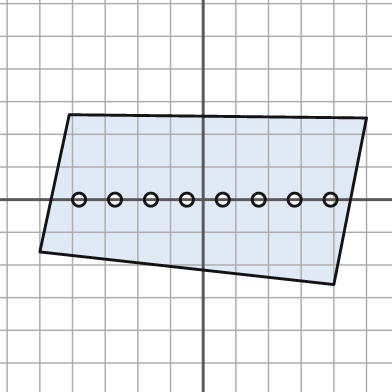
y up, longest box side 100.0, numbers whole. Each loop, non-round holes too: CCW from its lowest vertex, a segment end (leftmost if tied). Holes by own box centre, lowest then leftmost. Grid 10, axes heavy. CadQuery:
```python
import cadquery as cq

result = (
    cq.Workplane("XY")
    .moveTo(40.0, -26.0)
    .lineTo(50.0, 25.0)
    .lineTo(-41.0, 26.0)
    .lineTo(-50.0, -16.0)
    .close()
    .moveTo(-38.0, 0.0)
    .circle(2.0)
    .moveTo(-27.0, 0.0)
    .circle(2.0)
    .moveTo(-16.0, 0.0)
    .circle(2.0)
    .moveTo(-5.0, 0.0)
    .circle(2.0)
    .moveTo(6.0, 0.0)
    .circle(2.0)
    .moveTo(17.0, 0.0)
    .circle(2.0)
    .moveTo(28.0, 0.0)
    .circle(2.0)
    .moveTo(39.0, 0.0)
    .circle(2.0)
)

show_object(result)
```